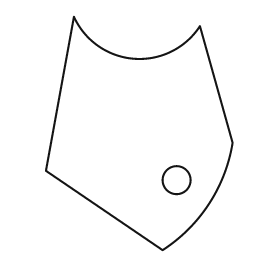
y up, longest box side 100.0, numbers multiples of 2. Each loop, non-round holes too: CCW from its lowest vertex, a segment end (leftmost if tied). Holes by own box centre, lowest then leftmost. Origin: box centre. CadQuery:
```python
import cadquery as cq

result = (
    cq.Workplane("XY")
    .moveTo(10.0, -50.0)
    .threePointArc((30.0, -30.0), (40.0, -4.0))
    .lineTo(26.0, 46.0)
    .threePointArc((-2.0, 32.0), (-28.0, 50.0))
    .lineTo(-40.0, -16.0)
    .close()
    .moveTo(16.0, -20.0)
    .circle(6.0)
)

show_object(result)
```